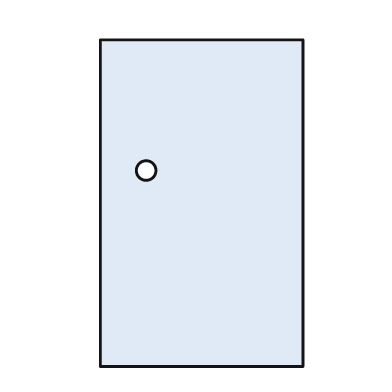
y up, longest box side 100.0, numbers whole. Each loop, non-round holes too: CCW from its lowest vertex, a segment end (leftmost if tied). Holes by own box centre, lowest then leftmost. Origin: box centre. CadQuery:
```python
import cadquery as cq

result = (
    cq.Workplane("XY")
    .moveTo(-31.0, -50.0)
    .lineTo(31.0, -50.0)
    .lineTo(31.0, 50.0)
    .lineTo(-31.0, 50.0)
    .close()
    .moveTo(-17.0, 10.0)
    .circle(3.0)
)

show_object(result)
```